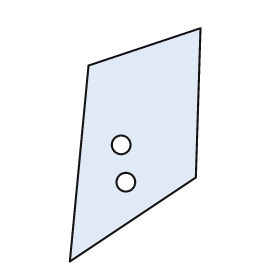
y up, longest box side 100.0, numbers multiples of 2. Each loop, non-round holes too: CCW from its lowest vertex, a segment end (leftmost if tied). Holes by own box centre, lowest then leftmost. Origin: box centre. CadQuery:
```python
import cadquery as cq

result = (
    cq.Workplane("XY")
    .moveTo(-28.0, -50.0)
    .lineTo(26.0, -14.0)
    .lineTo(28.0, 50.0)
    .lineTo(-20.0, 34.0)
    .close()
    .moveTo(-4.0, -16.0)
    .circle(4.0)
    .moveTo(-6.0, 0.0)
    .circle(4.0)
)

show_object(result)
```